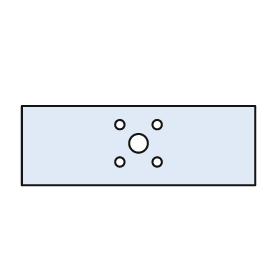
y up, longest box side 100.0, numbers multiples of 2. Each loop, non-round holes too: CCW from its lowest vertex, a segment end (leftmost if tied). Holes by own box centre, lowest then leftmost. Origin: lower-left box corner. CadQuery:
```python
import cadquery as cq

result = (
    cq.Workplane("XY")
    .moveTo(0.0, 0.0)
    .lineTo(100.0, 0.0)
    .lineTo(100.0, 34.0)
    .lineTo(0.0, 34.0)
    .close()
    .moveTo(42.0, 10.0)
    .circle(2.0)
    .moveTo(58.0, 10.0)
    .circle(2.0)
    .moveTo(50.0, 18.0)
    .circle(4.0)
    .moveTo(42.0, 26.0)
    .circle(2.0)
    .moveTo(58.0, 26.0)
    .circle(2.0)
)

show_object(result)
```